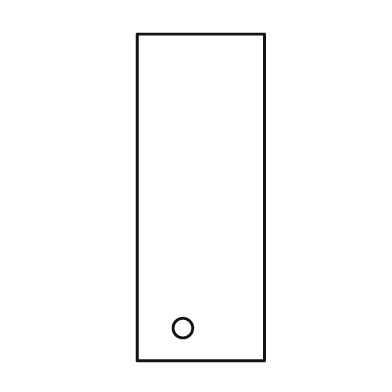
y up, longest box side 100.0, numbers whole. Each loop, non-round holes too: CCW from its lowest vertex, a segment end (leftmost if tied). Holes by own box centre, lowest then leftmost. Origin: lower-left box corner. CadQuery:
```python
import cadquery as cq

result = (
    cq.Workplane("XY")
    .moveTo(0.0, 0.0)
    .lineTo(39.0, 0.0)
    .lineTo(39.0, 100.0)
    .lineTo(0.0, 100.0)
    .close()
    .moveTo(14.0, 10.0)
    .circle(3.0)
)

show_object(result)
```